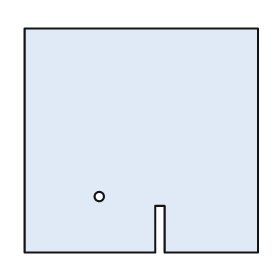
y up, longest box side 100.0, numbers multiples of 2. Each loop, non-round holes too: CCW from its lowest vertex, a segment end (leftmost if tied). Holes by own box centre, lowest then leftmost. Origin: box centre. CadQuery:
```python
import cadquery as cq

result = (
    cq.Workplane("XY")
    .moveTo(-50.0, -48.0)
    .lineTo(6.0, -48.0)
    .lineTo(6.0, -28.0)
    .lineTo(10.0, -28.0)
    .lineTo(10.0, -48.0)
    .lineTo(50.0, -48.0)
    .lineTo(50.0, 48.0)
    .lineTo(-50.0, 48.0)
    .close()
    .moveTo(-18.0, -24.0)
    .circle(2.0)
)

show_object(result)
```